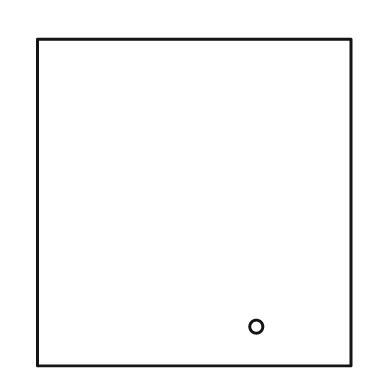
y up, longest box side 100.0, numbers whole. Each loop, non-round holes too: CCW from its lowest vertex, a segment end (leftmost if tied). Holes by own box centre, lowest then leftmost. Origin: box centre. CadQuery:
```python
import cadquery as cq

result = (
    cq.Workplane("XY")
    .moveTo(-48.0, -50.0)
    .lineTo(48.0, -50.0)
    .lineTo(48.0, 50.0)
    .lineTo(-48.0, 50.0)
    .close()
    .moveTo(19.0, -38.0)
    .circle(2.0)
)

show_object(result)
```